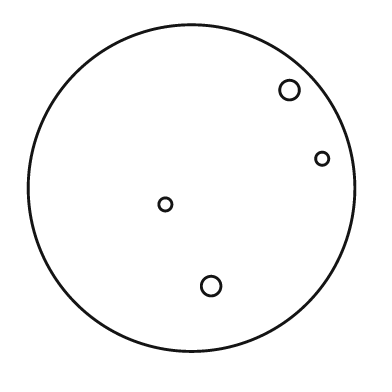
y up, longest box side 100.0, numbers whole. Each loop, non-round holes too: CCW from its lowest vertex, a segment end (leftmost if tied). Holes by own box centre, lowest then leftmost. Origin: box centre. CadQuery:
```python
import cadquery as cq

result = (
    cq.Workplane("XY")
    .moveTo(0.0, 0.0)
    .circle(50.0)
    .moveTo(6.0, -30.0)
    .circle(3.0)
    .moveTo(-8.0, -5.0)
    .circle(2.0)
    .moveTo(40.0, 9.0)
    .circle(2.0)
    .moveTo(30.0, 30.0)
    .circle(3.0)
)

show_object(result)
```